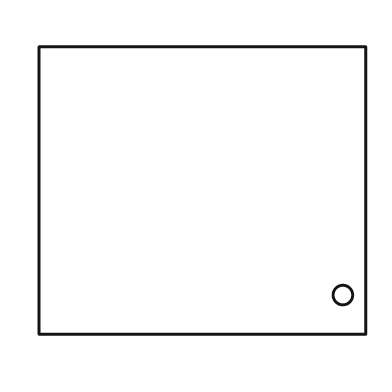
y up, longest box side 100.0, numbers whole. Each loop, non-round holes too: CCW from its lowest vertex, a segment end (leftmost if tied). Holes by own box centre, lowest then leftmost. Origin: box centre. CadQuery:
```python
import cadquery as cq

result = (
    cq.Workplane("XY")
    .moveTo(-50.0, -44.0)
    .lineTo(50.0, -44.0)
    .lineTo(50.0, 44.0)
    .lineTo(-50.0, 44.0)
    .close()
    .moveTo(43.0, -32.0)
    .circle(3.0)
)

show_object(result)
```